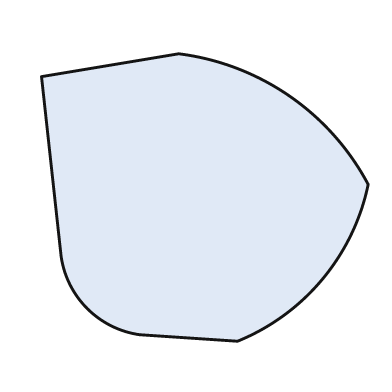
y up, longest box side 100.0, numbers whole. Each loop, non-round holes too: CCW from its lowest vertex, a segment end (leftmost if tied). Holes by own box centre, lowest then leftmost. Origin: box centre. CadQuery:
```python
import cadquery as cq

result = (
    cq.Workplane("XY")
    .moveTo(10.0, -44.0)
    .threePointArc((36.0, -25.0), (50.0, 4.0))
    .threePointArc((26.0, 31.0), (-8.0, 44.0))
    .lineTo(-50.0, 37.0)
    .lineTo(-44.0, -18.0)
    .threePointArc((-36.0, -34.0), (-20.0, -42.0))
    .close()
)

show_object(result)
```